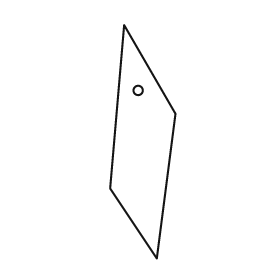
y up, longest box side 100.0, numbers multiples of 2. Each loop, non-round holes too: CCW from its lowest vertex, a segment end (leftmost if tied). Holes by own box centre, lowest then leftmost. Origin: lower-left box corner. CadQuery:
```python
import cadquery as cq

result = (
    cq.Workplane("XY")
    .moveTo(20.0, 0.0)
    .lineTo(28.0, 62.0)
    .lineTo(6.0, 100.0)
    .lineTo(0.0, 30.0)
    .close()
    .moveTo(12.0, 72.0)
    .circle(2.0)
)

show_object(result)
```